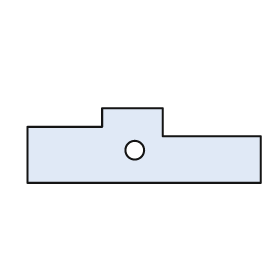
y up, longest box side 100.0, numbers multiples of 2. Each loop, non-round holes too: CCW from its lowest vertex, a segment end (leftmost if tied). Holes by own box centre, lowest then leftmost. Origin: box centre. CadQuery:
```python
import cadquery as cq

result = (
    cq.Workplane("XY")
    .moveTo(-50.0, -16.0)
    .lineTo(50.0, -16.0)
    .lineTo(50.0, 4.0)
    .lineTo(8.0, 4.0)
    .lineTo(8.0, 16.0)
    .lineTo(-18.0, 16.0)
    .lineTo(-18.0, 8.0)
    .lineTo(-50.0, 8.0)
    .close()
    .moveTo(-4.0, -2.0)
    .circle(4.0)
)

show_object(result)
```